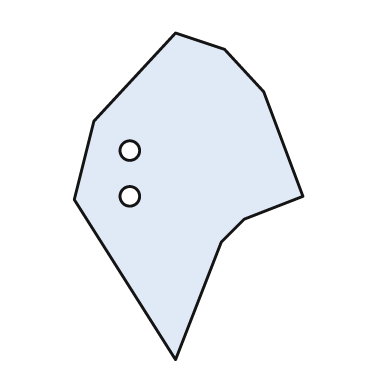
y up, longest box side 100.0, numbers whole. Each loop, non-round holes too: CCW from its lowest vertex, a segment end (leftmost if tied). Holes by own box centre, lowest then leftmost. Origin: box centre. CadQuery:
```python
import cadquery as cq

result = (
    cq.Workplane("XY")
    .moveTo(-4.0, -50.0)
    .lineTo(10.0, -14.0)
    .lineTo(17.0, -7.0)
    .lineTo(35.0, 0.0)
    .lineTo(23.0, 32.0)
    .lineTo(11.0, 45.0)
    .lineTo(-4.0, 50.0)
    .lineTo(-29.0, 23.0)
    .lineTo(-35.0, -1.0)
    .close()
    .moveTo(-18.0, 0.0)
    .circle(3.0)
    .moveTo(-18.0, 14.0)
    .circle(3.0)
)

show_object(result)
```